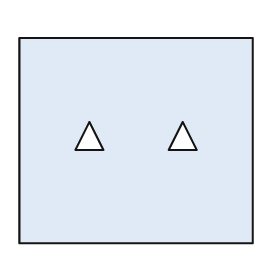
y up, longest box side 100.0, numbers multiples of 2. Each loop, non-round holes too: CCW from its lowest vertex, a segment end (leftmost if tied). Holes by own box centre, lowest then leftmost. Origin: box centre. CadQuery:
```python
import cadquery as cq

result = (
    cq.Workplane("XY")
    .moveTo(-50.0, -44.0)
    .lineTo(50.0, -44.0)
    .lineTo(50.0, 44.0)
    .lineTo(-50.0, 44.0)
    .close()
    .moveTo(-26.0, -4.0)
    .lineTo(-14.0, -4.0)
    .lineTo(-20.0, 8.0)
    .close()
    .moveTo(14.0, -4.0)
    .lineTo(26.0, -4.0)
    .lineTo(20.0, 8.0)
    .close()
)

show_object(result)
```